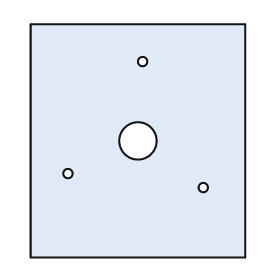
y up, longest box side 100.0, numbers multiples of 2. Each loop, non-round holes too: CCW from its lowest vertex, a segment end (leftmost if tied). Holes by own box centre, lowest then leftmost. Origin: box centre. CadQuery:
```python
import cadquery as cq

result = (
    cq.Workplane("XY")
    .moveTo(-46.0, -50.0)
    .lineTo(46.0, -50.0)
    .lineTo(46.0, 50.0)
    .lineTo(-46.0, 50.0)
    .close()
    .moveTo(28.0, -20.0)
    .circle(2.0)
    .moveTo(-30.0, -14.0)
    .circle(2.0)
    .moveTo(0.0, 0.0)
    .circle(8.0)
    .moveTo(2.0, 34.0)
    .circle(2.0)
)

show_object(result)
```